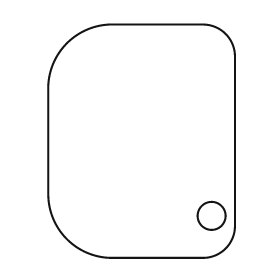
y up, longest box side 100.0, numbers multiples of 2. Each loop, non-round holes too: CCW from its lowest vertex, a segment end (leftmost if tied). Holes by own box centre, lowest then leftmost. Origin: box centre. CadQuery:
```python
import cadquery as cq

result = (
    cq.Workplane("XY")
    .moveTo(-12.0, -50.0)
    .lineTo(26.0, -50.0)
    .threePointArc((36.0, -46.0), (40.0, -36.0))
    .lineTo(40.0, 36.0)
    .threePointArc((36.0, 46.0), (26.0, 50.0))
    .lineTo(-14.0, 50.0)
    .threePointArc((-32.0, 42.0), (-40.0, 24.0))
    .lineTo(-40.0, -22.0)
    .threePointArc((-32.0, -42.0), (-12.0, -50.0))
    .close()
    .moveTo(30.0, -32.0)
    .circle(6.0)
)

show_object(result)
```